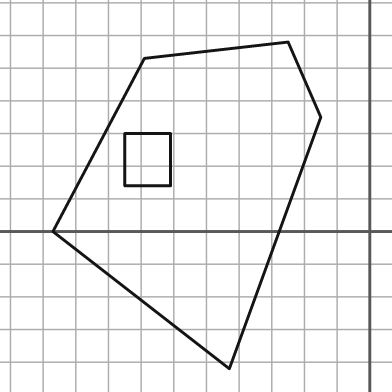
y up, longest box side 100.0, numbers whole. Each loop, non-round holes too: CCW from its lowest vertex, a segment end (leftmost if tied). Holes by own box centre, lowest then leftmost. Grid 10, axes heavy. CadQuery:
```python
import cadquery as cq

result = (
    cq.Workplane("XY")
    .moveTo(-43.0, -42.0)
    .lineTo(-15.0, 35.0)
    .lineTo(-25.0, 58.0)
    .lineTo(-69.0, 53.0)
    .lineTo(-97.0, 0.0)
    .close()
    .moveTo(-75.0, 14.0)
    .lineTo(-61.0, 14.0)
    .lineTo(-61.0, 30.0)
    .lineTo(-75.0, 30.0)
    .close()
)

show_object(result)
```